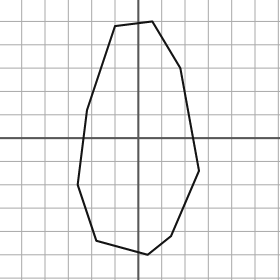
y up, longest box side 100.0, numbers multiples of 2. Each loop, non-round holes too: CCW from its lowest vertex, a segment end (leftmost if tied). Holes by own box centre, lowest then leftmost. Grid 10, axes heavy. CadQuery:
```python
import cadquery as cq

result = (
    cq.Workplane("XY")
    .moveTo(4.0, -50.0)
    .lineTo(14.0, -42.0)
    .lineTo(26.0, -14.0)
    .lineTo(18.0, 30.0)
    .lineTo(6.0, 50.0)
    .lineTo(-10.0, 48.0)
    .lineTo(-22.0, 12.0)
    .lineTo(-26.0, -20.0)
    .lineTo(-18.0, -44.0)
    .close()
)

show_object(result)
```